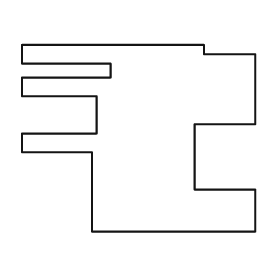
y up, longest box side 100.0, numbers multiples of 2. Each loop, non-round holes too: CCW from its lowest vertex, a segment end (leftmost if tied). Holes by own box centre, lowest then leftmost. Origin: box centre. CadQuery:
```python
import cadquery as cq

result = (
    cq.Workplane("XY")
    .moveTo(-20.0, -40.0)
    .lineTo(50.0, -40.0)
    .lineTo(50.0, -22.0)
    .lineTo(24.0, -22.0)
    .lineTo(24.0, 6.0)
    .lineTo(50.0, 6.0)
    .lineTo(50.0, 36.0)
    .lineTo(28.0, 36.0)
    .lineTo(28.0, 40.0)
    .lineTo(-50.0, 40.0)
    .lineTo(-50.0, 32.0)
    .lineTo(-12.0, 32.0)
    .lineTo(-12.0, 26.0)
    .lineTo(-50.0, 26.0)
    .lineTo(-50.0, 18.0)
    .lineTo(-18.0, 18.0)
    .lineTo(-18.0, 2.0)
    .lineTo(-50.0, 2.0)
    .lineTo(-50.0, -6.0)
    .lineTo(-20.0, -6.0)
    .close()
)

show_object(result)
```